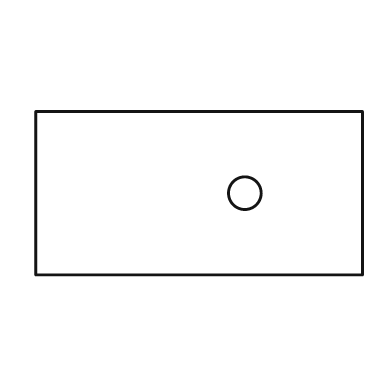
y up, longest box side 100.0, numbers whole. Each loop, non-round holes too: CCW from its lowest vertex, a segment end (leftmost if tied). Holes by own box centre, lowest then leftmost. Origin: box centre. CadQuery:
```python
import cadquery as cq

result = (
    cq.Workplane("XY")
    .moveTo(-50.0, -25.0)
    .lineTo(50.0, -25.0)
    .lineTo(50.0, 25.0)
    .lineTo(-50.0, 25.0)
    .close()
    .moveTo(14.0, 0.0)
    .circle(5.0)
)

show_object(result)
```